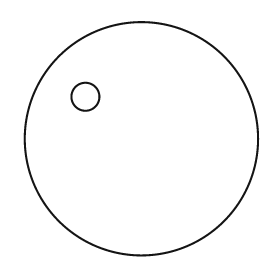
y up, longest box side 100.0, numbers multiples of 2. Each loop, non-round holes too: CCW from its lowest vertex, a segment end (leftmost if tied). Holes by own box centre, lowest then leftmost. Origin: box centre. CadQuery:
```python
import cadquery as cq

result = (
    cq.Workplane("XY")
    .moveTo(0.0, 0.0)
    .circle(50.0)
    .moveTo(-24.0, 18.0)
    .circle(6.0)
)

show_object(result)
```